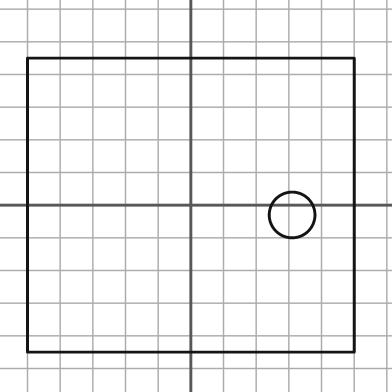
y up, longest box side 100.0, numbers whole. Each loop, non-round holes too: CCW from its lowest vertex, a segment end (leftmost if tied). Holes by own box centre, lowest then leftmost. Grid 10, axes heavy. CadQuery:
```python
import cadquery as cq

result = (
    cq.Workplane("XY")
    .moveTo(-50.0, -45.0)
    .lineTo(50.0, -45.0)
    .lineTo(50.0, 45.0)
    .lineTo(-50.0, 45.0)
    .close()
    .moveTo(31.0, -3.0)
    .circle(7.0)
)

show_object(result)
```